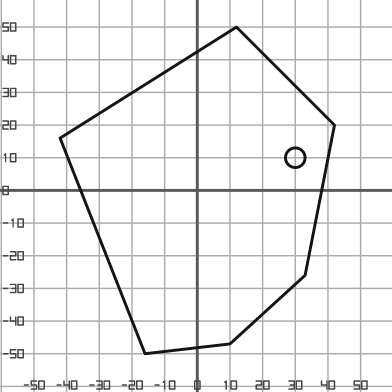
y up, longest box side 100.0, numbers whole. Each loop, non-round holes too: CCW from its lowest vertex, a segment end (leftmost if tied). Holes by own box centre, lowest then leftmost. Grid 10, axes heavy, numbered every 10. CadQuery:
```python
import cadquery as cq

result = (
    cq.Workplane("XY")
    .moveTo(-16.0, -50.0)
    .lineTo(10.0, -47.0)
    .lineTo(33.0, -26.0)
    .lineTo(42.0, 20.0)
    .lineTo(12.0, 50.0)
    .lineTo(-42.0, 16.0)
    .close()
    .moveTo(30.0, 10.0)
    .circle(3.0)
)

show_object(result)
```